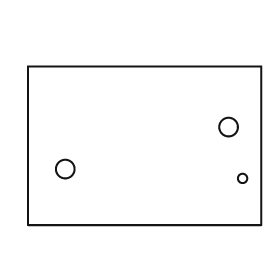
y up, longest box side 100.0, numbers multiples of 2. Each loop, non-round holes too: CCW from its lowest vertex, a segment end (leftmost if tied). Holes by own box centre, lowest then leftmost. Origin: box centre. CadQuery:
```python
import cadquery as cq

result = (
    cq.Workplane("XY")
    .moveTo(-50.0, -34.0)
    .lineTo(50.0, -34.0)
    .lineTo(50.0, 34.0)
    .lineTo(-50.0, 34.0)
    .close()
    .moveTo(42.0, -14.0)
    .circle(2.0)
    .moveTo(-34.0, -10.0)
    .circle(4.0)
    .moveTo(36.0, 8.0)
    .circle(4.0)
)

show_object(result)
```